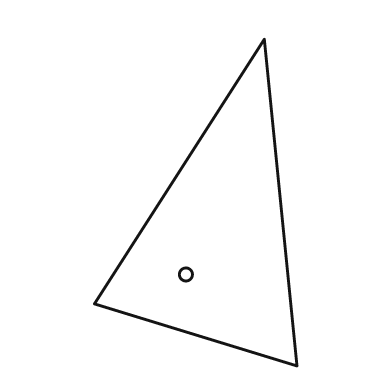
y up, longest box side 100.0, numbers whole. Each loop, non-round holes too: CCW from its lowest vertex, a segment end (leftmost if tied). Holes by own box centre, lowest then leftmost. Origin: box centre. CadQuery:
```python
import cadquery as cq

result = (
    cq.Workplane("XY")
    .moveTo(31.0, -50.0)
    .lineTo(21.0, 50.0)
    .lineTo(-31.0, -31.0)
    .close()
    .moveTo(-3.0, -22.0)
    .circle(2.0)
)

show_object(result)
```